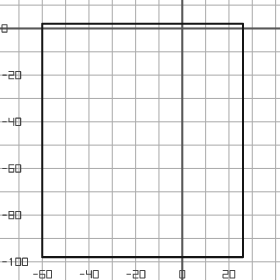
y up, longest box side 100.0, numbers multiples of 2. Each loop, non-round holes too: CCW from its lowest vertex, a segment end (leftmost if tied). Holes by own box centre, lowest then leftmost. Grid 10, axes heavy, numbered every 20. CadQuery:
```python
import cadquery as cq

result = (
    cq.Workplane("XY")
    .moveTo(-60.0, -98.0)
    .lineTo(26.0, -98.0)
    .lineTo(26.0, 2.0)
    .lineTo(-60.0, 2.0)
    .close()
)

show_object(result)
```